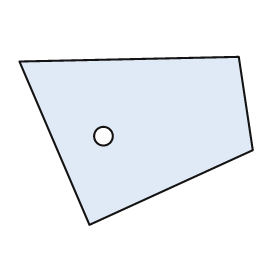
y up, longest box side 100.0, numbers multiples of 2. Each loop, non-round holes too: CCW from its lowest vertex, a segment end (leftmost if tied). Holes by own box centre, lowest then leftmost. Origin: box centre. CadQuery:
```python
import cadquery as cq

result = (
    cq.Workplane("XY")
    .moveTo(-20.0, -36.0)
    .lineTo(50.0, -4.0)
    .lineTo(44.0, 36.0)
    .lineTo(-50.0, 34.0)
    .close()
    .moveTo(-14.0, 2.0)
    .circle(4.0)
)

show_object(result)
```